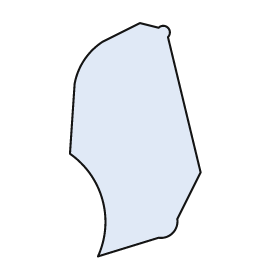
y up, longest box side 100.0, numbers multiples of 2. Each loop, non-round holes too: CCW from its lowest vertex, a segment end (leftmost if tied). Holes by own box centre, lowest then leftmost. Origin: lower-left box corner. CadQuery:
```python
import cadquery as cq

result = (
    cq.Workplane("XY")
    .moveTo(12.0, 0.0)
    .lineTo(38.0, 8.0)
    .threePointArc((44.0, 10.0), (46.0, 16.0))
    .lineTo(56.0, 36.0)
    .lineTo(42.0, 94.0)
    .threePointArc((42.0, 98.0), (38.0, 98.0))
    .lineTo(30.0, 100.0)
    .lineTo(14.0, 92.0)
    .threePointArc((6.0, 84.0), (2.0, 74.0))
    .lineTo(0.0, 44.0)
    .threePointArc((14.0, 24.0), (12.0, 0.0))
    .close()
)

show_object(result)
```